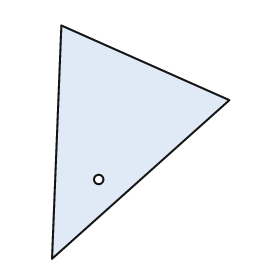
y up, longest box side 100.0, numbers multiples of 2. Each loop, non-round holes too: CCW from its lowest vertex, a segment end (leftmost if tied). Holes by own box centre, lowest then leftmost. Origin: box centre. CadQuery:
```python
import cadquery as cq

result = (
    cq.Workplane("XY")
    .moveTo(-38.0, -50.0)
    .lineTo(38.0, 18.0)
    .lineTo(-34.0, 50.0)
    .close()
    .moveTo(-18.0, -16.0)
    .circle(2.0)
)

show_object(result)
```